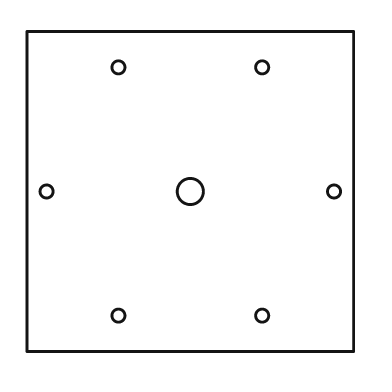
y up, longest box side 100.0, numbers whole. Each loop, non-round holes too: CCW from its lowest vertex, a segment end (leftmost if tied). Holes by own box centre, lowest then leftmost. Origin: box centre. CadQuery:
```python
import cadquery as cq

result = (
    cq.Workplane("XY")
    .moveTo(-50.0, -49.0)
    .lineTo(50.0, -49.0)
    .lineTo(50.0, 49.0)
    .lineTo(-50.0, 49.0)
    .close()
    .moveTo(-22.0, -38.0)
    .circle(2.0)
    .moveTo(22.0, -38.0)
    .circle(2.0)
    .moveTo(-44.0, 0.0)
    .circle(2.0)
    .moveTo(0.0, 0.0)
    .circle(4.0)
    .moveTo(44.0, 0.0)
    .circle(2.0)
    .moveTo(-22.0, 38.0)
    .circle(2.0)
    .moveTo(22.0, 38.0)
    .circle(2.0)
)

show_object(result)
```